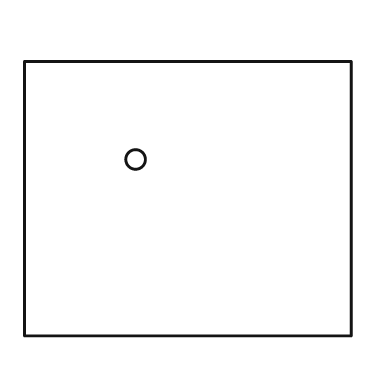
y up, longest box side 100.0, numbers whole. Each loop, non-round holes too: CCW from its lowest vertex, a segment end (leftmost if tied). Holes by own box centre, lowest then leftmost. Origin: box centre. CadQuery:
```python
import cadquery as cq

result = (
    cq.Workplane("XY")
    .moveTo(-50.0, -42.0)
    .lineTo(50.0, -42.0)
    .lineTo(50.0, 42.0)
    .lineTo(-50.0, 42.0)
    .close()
    .moveTo(-16.0, 12.0)
    .circle(3.0)
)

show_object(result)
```